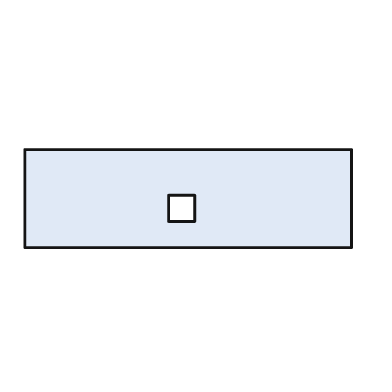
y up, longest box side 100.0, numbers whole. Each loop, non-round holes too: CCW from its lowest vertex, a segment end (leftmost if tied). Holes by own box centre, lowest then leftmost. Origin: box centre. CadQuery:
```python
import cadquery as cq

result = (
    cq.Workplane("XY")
    .moveTo(-50.0, -15.0)
    .lineTo(50.0, -15.0)
    .lineTo(50.0, 15.0)
    .lineTo(-50.0, 15.0)
    .close()
    .moveTo(-6.0, -7.0)
    .lineTo(2.0, -7.0)
    .lineTo(2.0, 1.0)
    .lineTo(-6.0, 1.0)
    .close()
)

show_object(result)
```